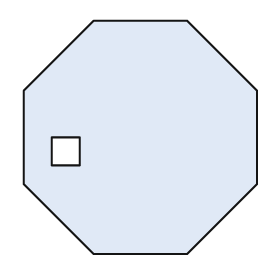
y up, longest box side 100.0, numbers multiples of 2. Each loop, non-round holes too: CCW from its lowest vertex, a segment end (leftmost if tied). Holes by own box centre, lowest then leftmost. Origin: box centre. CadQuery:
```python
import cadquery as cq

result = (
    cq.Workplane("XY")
    .moveTo(-20.0, -50.0)
    .lineTo(20.0, -50.0)
    .lineTo(50.0, -20.0)
    .lineTo(50.0, 20.0)
    .lineTo(20.0, 50.0)
    .lineTo(-20.0, 50.0)
    .lineTo(-50.0, 20.0)
    .lineTo(-50.0, -20.0)
    .close()
    .moveTo(-38.0, -12.0)
    .lineTo(-26.0, -12.0)
    .lineTo(-26.0, 0.0)
    .lineTo(-38.0, 0.0)
    .close()
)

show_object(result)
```